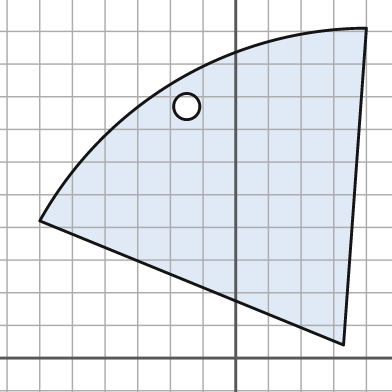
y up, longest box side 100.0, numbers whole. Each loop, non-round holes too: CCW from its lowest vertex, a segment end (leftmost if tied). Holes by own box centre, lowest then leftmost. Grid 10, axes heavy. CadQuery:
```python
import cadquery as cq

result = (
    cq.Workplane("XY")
    .moveTo(33.0, 4.0)
    .lineTo(40.0, 101.0)
    .threePointArc((-18.0, 85.0), (-60.0, 42.0))
    .close()
    .moveTo(-15.0, 77.0)
    .circle(4.0)
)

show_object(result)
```